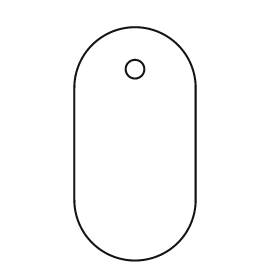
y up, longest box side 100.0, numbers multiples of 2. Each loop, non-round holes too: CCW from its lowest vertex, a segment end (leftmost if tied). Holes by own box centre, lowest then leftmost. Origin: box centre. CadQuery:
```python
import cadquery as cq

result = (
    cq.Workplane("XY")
    .moveTo(-26.0, -24.0)
    .threePointArc((0.0, -50.0), (26.0, -24.0))
    .lineTo(26.0, 24.0)
    .threePointArc((0.0, 50.0), (-26.0, 24.0))
    .close()
    .moveTo(0.0, 32.0)
    .circle(4.0)
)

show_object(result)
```